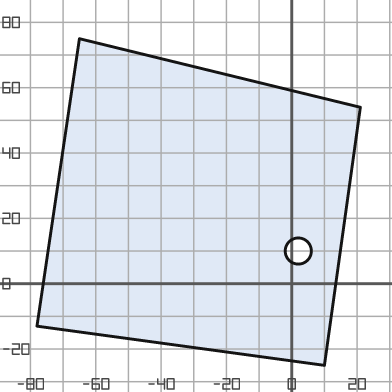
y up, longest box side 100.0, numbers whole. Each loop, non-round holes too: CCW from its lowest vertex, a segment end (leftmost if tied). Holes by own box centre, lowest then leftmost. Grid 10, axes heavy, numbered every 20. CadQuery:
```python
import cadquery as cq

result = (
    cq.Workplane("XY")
    .moveTo(10.0, -25.0)
    .lineTo(21.0, 54.0)
    .lineTo(-65.0, 75.0)
    .lineTo(-78.0, -13.0)
    .close()
    .moveTo(2.0, 10.0)
    .circle(4.0)
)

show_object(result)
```